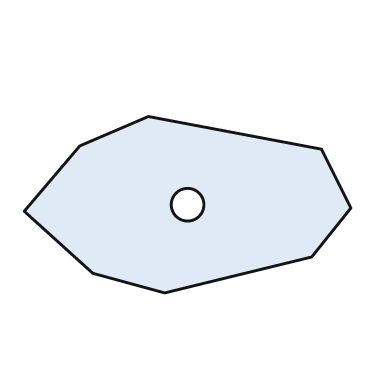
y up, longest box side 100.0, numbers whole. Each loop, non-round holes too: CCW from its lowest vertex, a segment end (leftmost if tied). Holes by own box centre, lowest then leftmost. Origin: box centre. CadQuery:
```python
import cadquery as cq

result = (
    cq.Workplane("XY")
    .moveTo(-7.0, -27.0)
    .lineTo(38.0, -16.0)
    .lineTo(50.0, -1.0)
    .lineTo(41.0, 17.0)
    .lineTo(-12.0, 27.0)
    .lineTo(-33.0, 18.0)
    .lineTo(-50.0, -2.0)
    .lineTo(-29.0, -21.0)
    .close()
    .moveTo(0.0, 0.0)
    .circle(5.0)
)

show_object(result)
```